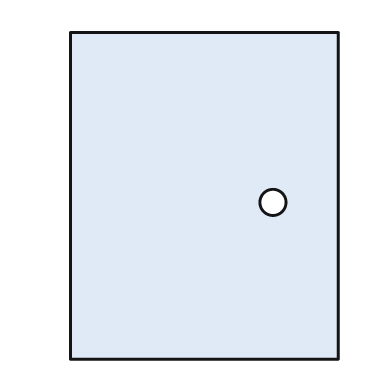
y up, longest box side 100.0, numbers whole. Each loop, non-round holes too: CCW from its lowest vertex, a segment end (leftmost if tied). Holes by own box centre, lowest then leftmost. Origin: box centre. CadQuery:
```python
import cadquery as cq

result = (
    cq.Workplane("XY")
    .moveTo(-41.0, -50.0)
    .lineTo(41.0, -50.0)
    .lineTo(41.0, 50.0)
    .lineTo(-41.0, 50.0)
    .close()
    .moveTo(21.0, -2.0)
    .circle(4.0)
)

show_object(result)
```